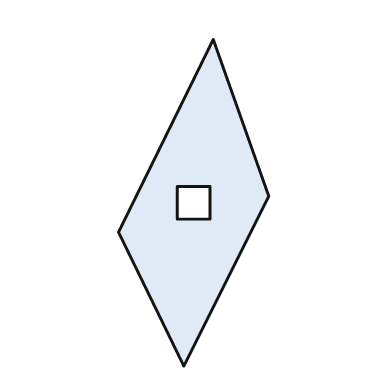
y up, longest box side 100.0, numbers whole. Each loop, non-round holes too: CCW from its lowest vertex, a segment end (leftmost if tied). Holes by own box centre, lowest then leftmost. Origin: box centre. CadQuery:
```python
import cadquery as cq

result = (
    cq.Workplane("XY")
    .moveTo(-3.0, -50.0)
    .lineTo(23.0, 2.0)
    .lineTo(6.0, 50.0)
    .lineTo(-23.0, -9.0)
    .close()
    .moveTo(-5.0, -5.0)
    .lineTo(5.0, -5.0)
    .lineTo(5.0, 5.0)
    .lineTo(-5.0, 5.0)
    .close()
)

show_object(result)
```